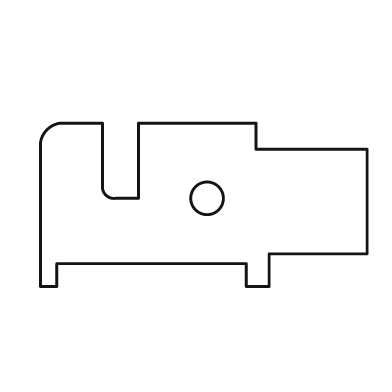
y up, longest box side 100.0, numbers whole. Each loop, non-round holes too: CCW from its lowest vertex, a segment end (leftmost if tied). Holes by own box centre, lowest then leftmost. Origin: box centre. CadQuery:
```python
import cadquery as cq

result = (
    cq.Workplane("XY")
    .moveTo(-50.0, -25.0)
    .lineTo(-45.0, -25.0)
    .lineTo(-45.0, -18.0)
    .lineTo(13.0, -18.0)
    .lineTo(13.0, -25.0)
    .lineTo(20.0, -25.0)
    .lineTo(20.0, -15.0)
    .lineTo(50.0, -15.0)
    .lineTo(50.0, 17.0)
    .lineTo(16.0, 17.0)
    .lineTo(16.0, 25.0)
    .lineTo(-20.0, 25.0)
    .lineTo(-20.0, 2.0)
    .lineTo(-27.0, 2.0)
    .threePointArc((-30.0, 3.0), (-31.0, 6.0))
    .lineTo(-31.0, 25.0)
    .lineTo(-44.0, 25.0)
    .threePointArc((-48.0, 23.0), (-50.0, 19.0))
    .close()
    .moveTo(1.0, 2.0)
    .circle(5.0)
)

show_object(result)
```